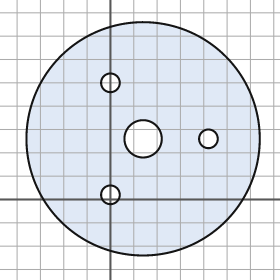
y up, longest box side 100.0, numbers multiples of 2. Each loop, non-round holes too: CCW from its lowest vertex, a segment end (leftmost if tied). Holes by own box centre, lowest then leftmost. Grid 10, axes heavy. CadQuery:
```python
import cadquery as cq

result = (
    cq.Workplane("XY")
    .moveTo(14.0, 26.0)
    .circle(50.0)
    .moveTo(0.0, 2.0)
    .circle(4.0)
    .moveTo(14.0, 26.0)
    .circle(8.0)
    .moveTo(42.0, 26.0)
    .circle(4.0)
    .moveTo(0.0, 50.0)
    .circle(4.0)
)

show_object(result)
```